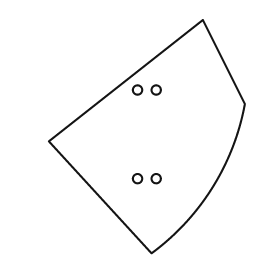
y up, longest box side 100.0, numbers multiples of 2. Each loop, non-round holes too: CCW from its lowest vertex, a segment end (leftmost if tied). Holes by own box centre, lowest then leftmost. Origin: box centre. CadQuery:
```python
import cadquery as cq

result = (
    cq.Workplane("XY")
    .moveTo(2.0, -50.0)
    .threePointArc((28.0, -22.0), (42.0, 14.0))
    .lineTo(24.0, 50.0)
    .lineTo(-42.0, -2.0)
    .close()
    .moveTo(-4.0, -18.0)
    .circle(2.0)
    .moveTo(4.0, -18.0)
    .circle(2.0)
    .moveTo(-4.0, 20.0)
    .circle(2.0)
    .moveTo(4.0, 20.0)
    .circle(2.0)
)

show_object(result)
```